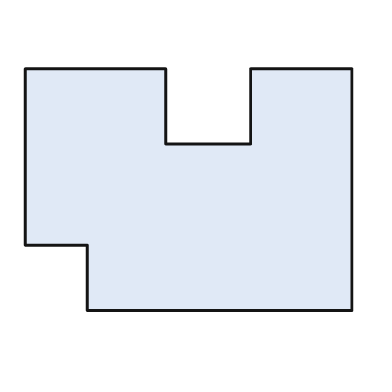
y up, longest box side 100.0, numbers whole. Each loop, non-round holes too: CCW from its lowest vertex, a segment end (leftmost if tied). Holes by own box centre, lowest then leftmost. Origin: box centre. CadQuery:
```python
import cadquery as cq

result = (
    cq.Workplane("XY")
    .moveTo(-31.0, -37.0)
    .lineTo(50.0, -37.0)
    .lineTo(50.0, 37.0)
    .lineTo(19.0, 37.0)
    .lineTo(19.0, 14.0)
    .lineTo(-7.0, 14.0)
    .lineTo(-7.0, 37.0)
    .lineTo(-50.0, 37.0)
    .lineTo(-50.0, -17.0)
    .lineTo(-31.0, -17.0)
    .close()
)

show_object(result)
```